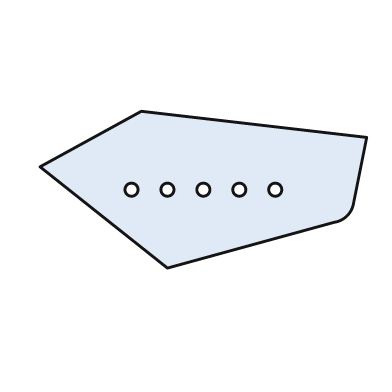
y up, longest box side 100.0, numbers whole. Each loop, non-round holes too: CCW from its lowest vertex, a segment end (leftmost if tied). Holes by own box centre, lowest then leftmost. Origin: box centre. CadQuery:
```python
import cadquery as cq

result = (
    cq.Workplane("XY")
    .moveTo(-11.0, -24.0)
    .lineTo(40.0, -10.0)
    .threePointArc((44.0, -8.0), (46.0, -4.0))
    .lineTo(50.0, 16.0)
    .lineTo(-19.0, 24.0)
    .lineTo(-50.0, 7.0)
    .close()
    .moveTo(-22.0, 0.0)
    .circle(2.0)
    .moveTo(-11.0, 0.0)
    .circle(2.0)
    .moveTo(0.0, 0.0)
    .circle(2.0)
    .moveTo(11.0, 0.0)
    .circle(2.0)
    .moveTo(22.0, 0.0)
    .circle(2.0)
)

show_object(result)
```